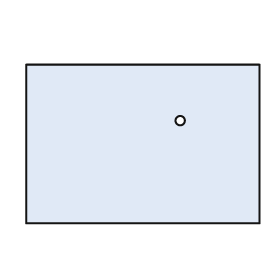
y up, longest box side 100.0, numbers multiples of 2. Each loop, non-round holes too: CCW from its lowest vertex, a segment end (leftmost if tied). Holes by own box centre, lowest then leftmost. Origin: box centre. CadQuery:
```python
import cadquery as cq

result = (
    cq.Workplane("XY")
    .moveTo(-50.0, -34.0)
    .lineTo(50.0, -34.0)
    .lineTo(50.0, 34.0)
    .lineTo(-50.0, 34.0)
    .close()
    .moveTo(16.0, 10.0)
    .circle(2.0)
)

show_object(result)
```